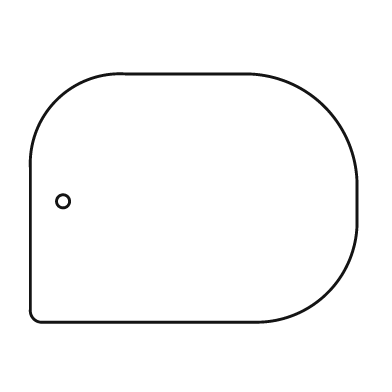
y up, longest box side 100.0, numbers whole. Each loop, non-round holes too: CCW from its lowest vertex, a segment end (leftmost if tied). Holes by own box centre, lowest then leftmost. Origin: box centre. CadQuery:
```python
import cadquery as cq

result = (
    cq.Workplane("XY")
    .moveTo(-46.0, -38.0)
    .lineTo(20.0, -38.0)
    .threePointArc((41.0, -29.0), (50.0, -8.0))
    .lineTo(50.0, 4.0)
    .threePointArc((40.0, 28.0), (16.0, 38.0))
    .lineTo(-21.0, 38.0)
    .threePointArc((-42.0, 30.0), (-50.0, 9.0))
    .lineTo(-50.0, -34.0)
    .threePointArc((-49.0, -37.0), (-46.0, -38.0))
    .close()
    .moveTo(-40.0, -1.0)
    .circle(2.0)
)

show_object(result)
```